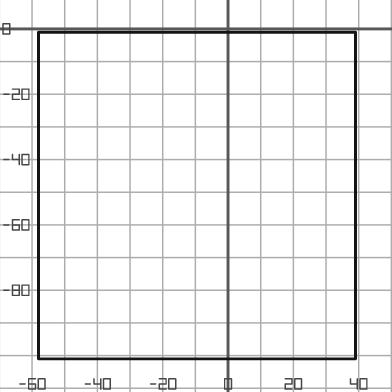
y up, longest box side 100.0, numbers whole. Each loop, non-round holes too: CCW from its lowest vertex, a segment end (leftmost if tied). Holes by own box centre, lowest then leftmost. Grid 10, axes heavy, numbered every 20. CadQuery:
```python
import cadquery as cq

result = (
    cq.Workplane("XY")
    .moveTo(-58.0, -101.0)
    .lineTo(39.0, -101.0)
    .lineTo(39.0, -1.0)
    .lineTo(-58.0, -1.0)
    .close()
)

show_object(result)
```